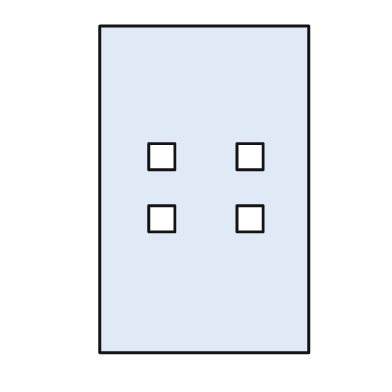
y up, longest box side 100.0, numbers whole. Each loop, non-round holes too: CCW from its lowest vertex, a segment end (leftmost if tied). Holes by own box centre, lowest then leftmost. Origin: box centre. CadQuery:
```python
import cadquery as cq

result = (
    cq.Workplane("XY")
    .moveTo(-32.0, -50.0)
    .lineTo(32.0, -50.0)
    .lineTo(32.0, 50.0)
    .lineTo(-32.0, 50.0)
    .close()
    .moveTo(-17.0, -13.0)
    .lineTo(-9.0, -13.0)
    .lineTo(-9.0, -5.0)
    .lineTo(-17.0, -5.0)
    .close()
    .moveTo(10.0, -13.0)
    .lineTo(18.0, -13.0)
    .lineTo(18.0, -5.0)
    .lineTo(10.0, -5.0)
    .close()
    .moveTo(-17.0, 6.0)
    .lineTo(-9.0, 6.0)
    .lineTo(-9.0, 14.0)
    .lineTo(-17.0, 14.0)
    .close()
    .moveTo(10.0, 6.0)
    .lineTo(18.0, 6.0)
    .lineTo(18.0, 14.0)
    .lineTo(10.0, 14.0)
    .close()
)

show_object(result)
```